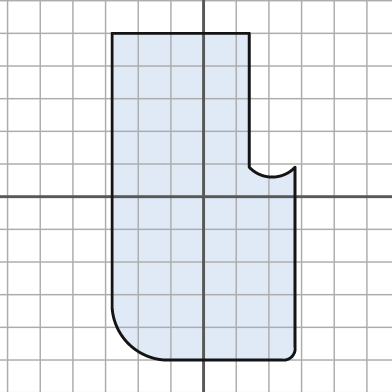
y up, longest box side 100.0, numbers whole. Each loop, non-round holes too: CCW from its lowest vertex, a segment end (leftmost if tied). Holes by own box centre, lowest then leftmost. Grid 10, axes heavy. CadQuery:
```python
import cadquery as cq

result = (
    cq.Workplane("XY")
    .moveTo(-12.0, -50.0)
    .lineTo(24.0, -50.0)
    .threePointArc((27.0, -49.0), (28.0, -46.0))
    .lineTo(28.0, 9.0)
    .threePointArc((21.0, 6.0), (14.0, 9.0))
    .lineTo(14.0, 50.0)
    .lineTo(-28.0, 50.0)
    .lineTo(-28.0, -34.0)
    .threePointArc((-23.0, -45.0), (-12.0, -50.0))
    .close()
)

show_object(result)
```